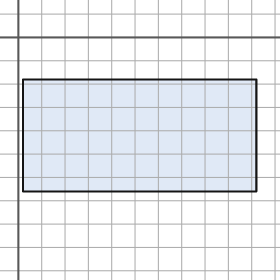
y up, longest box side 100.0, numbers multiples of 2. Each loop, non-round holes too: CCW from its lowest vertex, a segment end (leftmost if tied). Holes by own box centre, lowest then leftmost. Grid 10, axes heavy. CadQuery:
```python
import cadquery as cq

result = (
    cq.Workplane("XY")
    .moveTo(2.0, -66.0)
    .lineTo(102.0, -66.0)
    .lineTo(102.0, -18.0)
    .lineTo(2.0, -18.0)
    .close()
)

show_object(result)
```